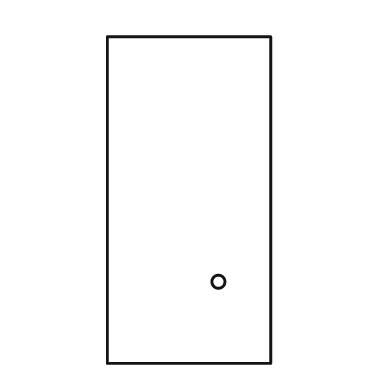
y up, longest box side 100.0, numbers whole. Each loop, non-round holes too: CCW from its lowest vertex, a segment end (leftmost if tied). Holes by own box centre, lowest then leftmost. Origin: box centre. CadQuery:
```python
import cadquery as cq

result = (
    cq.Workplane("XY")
    .moveTo(-25.0, -50.0)
    .lineTo(25.0, -50.0)
    .lineTo(25.0, 50.0)
    .lineTo(-25.0, 50.0)
    .close()
    .moveTo(9.0, -25.0)
    .circle(2.0)
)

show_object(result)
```